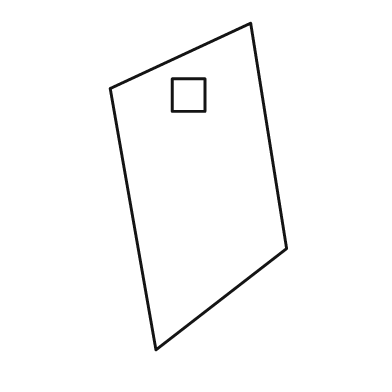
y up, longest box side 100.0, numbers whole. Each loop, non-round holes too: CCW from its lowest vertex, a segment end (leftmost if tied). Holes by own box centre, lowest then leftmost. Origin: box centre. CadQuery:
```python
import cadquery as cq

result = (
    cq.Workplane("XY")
    .moveTo(-13.0, -50.0)
    .lineTo(27.0, -19.0)
    .lineTo(16.0, 50.0)
    .lineTo(-27.0, 30.0)
    .close()
    .moveTo(-8.0, 23.0)
    .lineTo(2.0, 23.0)
    .lineTo(2.0, 33.0)
    .lineTo(-8.0, 33.0)
    .close()
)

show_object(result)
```